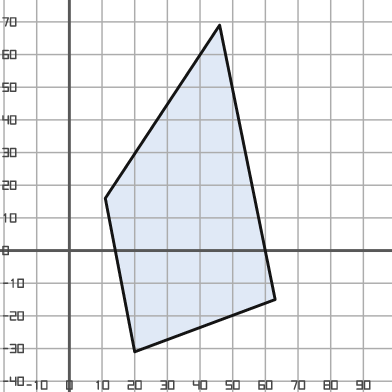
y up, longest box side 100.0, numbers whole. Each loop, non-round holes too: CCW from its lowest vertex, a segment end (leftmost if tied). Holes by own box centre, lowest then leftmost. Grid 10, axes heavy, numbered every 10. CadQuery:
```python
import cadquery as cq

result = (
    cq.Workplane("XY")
    .moveTo(20.0, -31.0)
    .lineTo(63.0, -15.0)
    .lineTo(46.0, 69.0)
    .lineTo(11.0, 16.0)
    .close()
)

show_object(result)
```